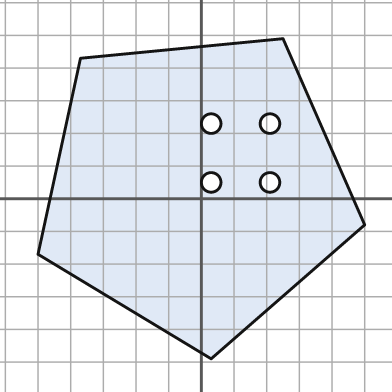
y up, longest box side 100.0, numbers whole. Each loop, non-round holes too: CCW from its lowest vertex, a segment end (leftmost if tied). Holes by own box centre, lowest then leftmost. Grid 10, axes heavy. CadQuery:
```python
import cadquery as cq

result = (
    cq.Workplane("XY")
    .moveTo(3.0, -49.0)
    .lineTo(50.0, -8.0)
    .lineTo(25.0, 49.0)
    .lineTo(-37.0, 43.0)
    .lineTo(-50.0, -17.0)
    .close()
    .moveTo(3.0, 5.0)
    .circle(3.0)
    .moveTo(21.0, 5.0)
    .circle(3.0)
    .moveTo(3.0, 23.0)
    .circle(3.0)
    .moveTo(21.0, 23.0)
    .circle(3.0)
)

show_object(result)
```